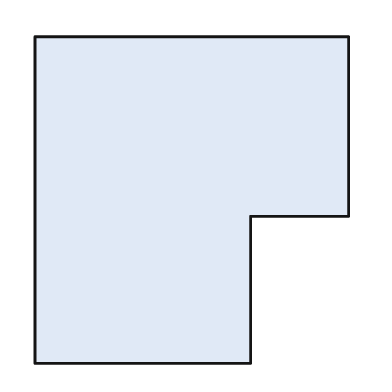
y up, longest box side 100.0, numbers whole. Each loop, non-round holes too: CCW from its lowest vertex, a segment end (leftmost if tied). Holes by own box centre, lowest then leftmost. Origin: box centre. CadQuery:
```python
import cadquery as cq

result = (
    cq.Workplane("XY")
    .moveTo(-48.0, -50.0)
    .lineTo(18.0, -50.0)
    .lineTo(18.0, -5.0)
    .lineTo(48.0, -5.0)
    .lineTo(48.0, 50.0)
    .lineTo(-48.0, 50.0)
    .close()
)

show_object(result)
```